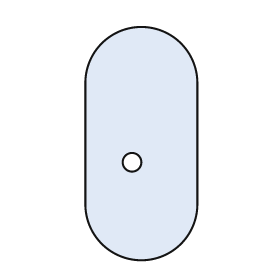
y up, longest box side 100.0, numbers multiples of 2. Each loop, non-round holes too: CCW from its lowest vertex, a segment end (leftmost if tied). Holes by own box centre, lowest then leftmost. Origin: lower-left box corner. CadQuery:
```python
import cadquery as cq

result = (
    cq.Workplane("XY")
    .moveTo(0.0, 24.0)
    .threePointArc((24.0, 0.0), (48.0, 24.0))
    .lineTo(48.0, 76.0)
    .threePointArc((24.0, 100.0), (0.0, 76.0))
    .close()
    .moveTo(20.0, 42.0)
    .circle(4.0)
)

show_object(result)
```